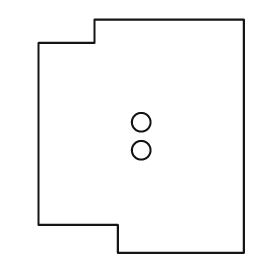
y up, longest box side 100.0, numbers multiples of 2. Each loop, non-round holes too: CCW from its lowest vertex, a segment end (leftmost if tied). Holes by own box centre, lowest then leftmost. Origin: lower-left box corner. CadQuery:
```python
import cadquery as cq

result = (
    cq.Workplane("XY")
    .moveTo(34.0, 0.0)
    .lineTo(88.0, 0.0)
    .lineTo(88.0, 100.0)
    .lineTo(24.0, 100.0)
    .lineTo(24.0, 90.0)
    .lineTo(0.0, 90.0)
    .lineTo(0.0, 12.0)
    .lineTo(34.0, 12.0)
    .close()
    .moveTo(44.0, 44.0)
    .circle(4.0)
    .moveTo(44.0, 56.0)
    .circle(4.0)
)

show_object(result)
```